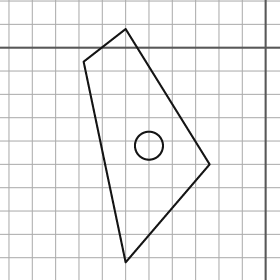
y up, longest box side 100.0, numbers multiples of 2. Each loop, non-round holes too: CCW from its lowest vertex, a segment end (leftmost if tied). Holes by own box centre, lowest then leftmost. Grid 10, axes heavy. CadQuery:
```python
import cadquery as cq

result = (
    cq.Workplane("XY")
    .moveTo(-60.0, -92.0)
    .lineTo(-24.0, -50.0)
    .lineTo(-60.0, 8.0)
    .lineTo(-78.0, -6.0)
    .close()
    .moveTo(-50.0, -42.0)
    .circle(6.0)
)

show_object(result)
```